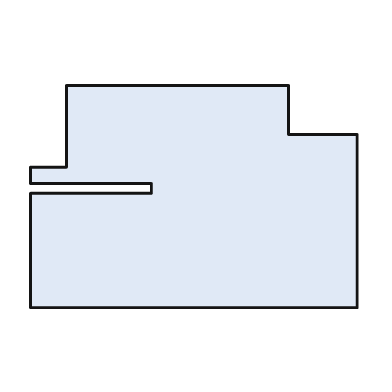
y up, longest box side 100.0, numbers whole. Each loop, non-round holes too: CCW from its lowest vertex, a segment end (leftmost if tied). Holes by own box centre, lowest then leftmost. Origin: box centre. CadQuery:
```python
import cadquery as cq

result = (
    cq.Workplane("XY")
    .moveTo(-50.0, -34.0)
    .lineTo(50.0, -34.0)
    .lineTo(50.0, 19.0)
    .lineTo(29.0, 19.0)
    .lineTo(29.0, 34.0)
    .lineTo(-39.0, 34.0)
    .lineTo(-39.0, 9.0)
    .lineTo(-50.0, 9.0)
    .lineTo(-50.0, 4.0)
    .lineTo(-13.0, 4.0)
    .lineTo(-13.0, 1.0)
    .lineTo(-50.0, 1.0)
    .close()
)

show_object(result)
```